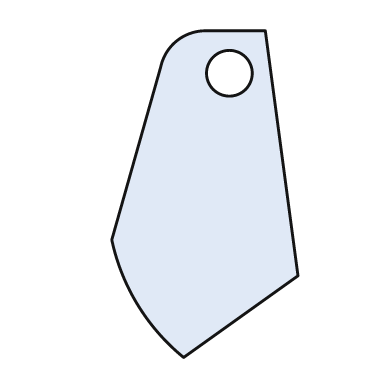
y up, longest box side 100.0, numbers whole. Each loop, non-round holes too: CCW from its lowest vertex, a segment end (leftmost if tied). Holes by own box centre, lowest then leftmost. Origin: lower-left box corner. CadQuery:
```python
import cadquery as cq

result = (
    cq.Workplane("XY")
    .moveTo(22.0, 0.0)
    .lineTo(57.0, 25.0)
    .lineTo(47.0, 100.0)
    .lineTo(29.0, 100.0)
    .threePointArc((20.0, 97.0), (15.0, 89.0))
    .lineTo(0.0, 36.0)
    .threePointArc((8.0, 16.0), (22.0, 0.0))
    .close()
    .moveTo(36.0, 87.0)
    .circle(7.0)
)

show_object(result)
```